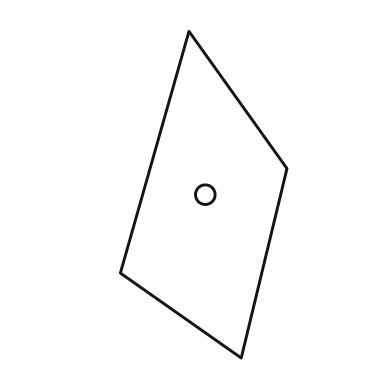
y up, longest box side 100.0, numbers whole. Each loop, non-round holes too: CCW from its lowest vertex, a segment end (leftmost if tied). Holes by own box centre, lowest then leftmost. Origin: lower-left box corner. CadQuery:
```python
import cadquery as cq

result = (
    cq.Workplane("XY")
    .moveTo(37.0, 0.0)
    .lineTo(51.0, 58.0)
    .lineTo(21.0, 100.0)
    .lineTo(0.0, 26.0)
    .close()
    .moveTo(26.0, 50.0)
    .circle(3.0)
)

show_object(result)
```